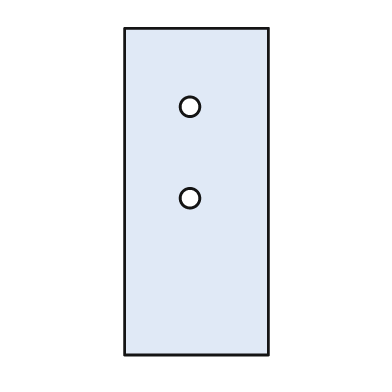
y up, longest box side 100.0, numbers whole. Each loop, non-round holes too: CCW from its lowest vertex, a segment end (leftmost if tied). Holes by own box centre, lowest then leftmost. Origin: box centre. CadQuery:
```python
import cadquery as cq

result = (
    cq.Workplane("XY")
    .moveTo(-22.0, -50.0)
    .lineTo(22.0, -50.0)
    .lineTo(22.0, 50.0)
    .lineTo(-22.0, 50.0)
    .close()
    .moveTo(-2.0, -2.0)
    .circle(3.0)
    .moveTo(-2.0, 26.0)
    .circle(3.0)
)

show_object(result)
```